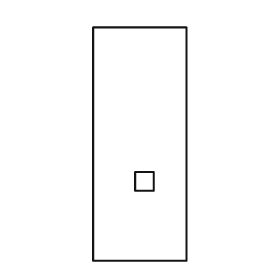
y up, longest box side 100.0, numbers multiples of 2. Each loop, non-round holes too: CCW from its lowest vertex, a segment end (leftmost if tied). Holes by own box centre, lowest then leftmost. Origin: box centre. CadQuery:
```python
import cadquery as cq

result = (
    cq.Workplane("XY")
    .moveTo(-20.0, -50.0)
    .lineTo(20.0, -50.0)
    .lineTo(20.0, 50.0)
    .lineTo(-20.0, 50.0)
    .close()
    .moveTo(-2.0, -20.0)
    .lineTo(6.0, -20.0)
    .lineTo(6.0, -12.0)
    .lineTo(-2.0, -12.0)
    .close()
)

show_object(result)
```